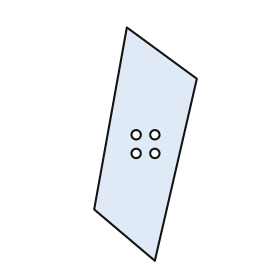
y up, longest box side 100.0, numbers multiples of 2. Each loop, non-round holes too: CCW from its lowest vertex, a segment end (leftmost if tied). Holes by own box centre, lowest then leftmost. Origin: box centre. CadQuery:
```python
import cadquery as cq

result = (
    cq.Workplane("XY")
    .moveTo(4.0, -50.0)
    .lineTo(22.0, 28.0)
    .lineTo(-8.0, 50.0)
    .lineTo(-22.0, -28.0)
    .close()
    .moveTo(-4.0, -4.0)
    .circle(2.0)
    .moveTo(4.0, -4.0)
    .circle(2.0)
    .moveTo(-4.0, 4.0)
    .circle(2.0)
    .moveTo(4.0, 4.0)
    .circle(2.0)
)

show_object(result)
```